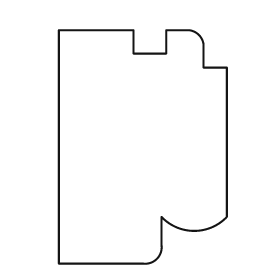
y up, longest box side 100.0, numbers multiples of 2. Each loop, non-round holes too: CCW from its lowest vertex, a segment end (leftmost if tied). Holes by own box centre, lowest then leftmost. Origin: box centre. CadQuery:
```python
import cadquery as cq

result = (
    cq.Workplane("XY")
    .moveTo(-36.0, -50.0)
    .lineTo(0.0, -50.0)
    .threePointArc((6.0, -48.0), (8.0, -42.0))
    .lineTo(8.0, -30.0)
    .threePointArc((22.0, -36.0), (36.0, -30.0))
    .lineTo(36.0, 34.0)
    .lineTo(26.0, 34.0)
    .lineTo(26.0, 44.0)
    .threePointArc((24.0, 48.0), (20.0, 50.0))
    .lineTo(10.0, 50.0)
    .lineTo(10.0, 40.0)
    .lineTo(-4.0, 40.0)
    .lineTo(-4.0, 50.0)
    .lineTo(-36.0, 50.0)
    .close()
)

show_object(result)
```